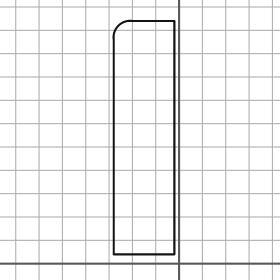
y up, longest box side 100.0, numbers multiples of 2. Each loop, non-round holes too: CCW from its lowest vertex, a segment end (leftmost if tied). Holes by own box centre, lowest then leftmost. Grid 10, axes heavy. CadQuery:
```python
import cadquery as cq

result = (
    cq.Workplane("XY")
    .moveTo(-28.0, 4.0)
    .lineTo(-2.0, 4.0)
    .lineTo(-2.0, 104.0)
    .lineTo(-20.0, 104.0)
    .threePointArc((-26.0, 102.0), (-28.0, 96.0))
    .close()
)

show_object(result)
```